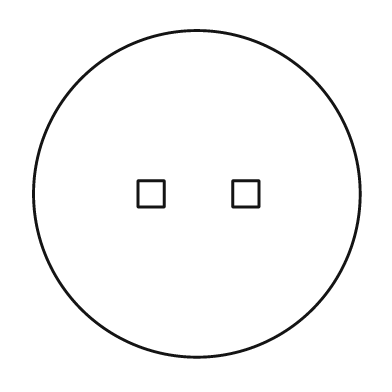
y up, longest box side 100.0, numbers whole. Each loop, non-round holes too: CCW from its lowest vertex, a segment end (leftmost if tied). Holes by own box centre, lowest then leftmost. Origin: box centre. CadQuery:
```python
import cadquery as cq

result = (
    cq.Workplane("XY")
    .moveTo(0.0, 0.0)
    .circle(50.0)
    .moveTo(-18.0, -4.0)
    .lineTo(-10.0, -4.0)
    .lineTo(-10.0, 4.0)
    .lineTo(-18.0, 4.0)
    .close()
    .moveTo(11.0, -4.0)
    .lineTo(19.0, -4.0)
    .lineTo(19.0, 4.0)
    .lineTo(11.0, 4.0)
    .close()
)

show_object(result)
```